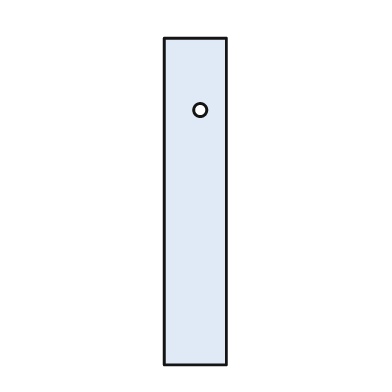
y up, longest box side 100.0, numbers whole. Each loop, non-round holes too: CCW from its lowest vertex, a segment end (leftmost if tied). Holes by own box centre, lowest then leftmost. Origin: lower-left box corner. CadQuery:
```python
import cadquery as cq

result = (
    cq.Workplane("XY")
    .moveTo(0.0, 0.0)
    .lineTo(19.0, 0.0)
    .lineTo(19.0, 100.0)
    .lineTo(0.0, 100.0)
    .close()
    .moveTo(11.0, 78.0)
    .circle(2.0)
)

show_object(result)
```